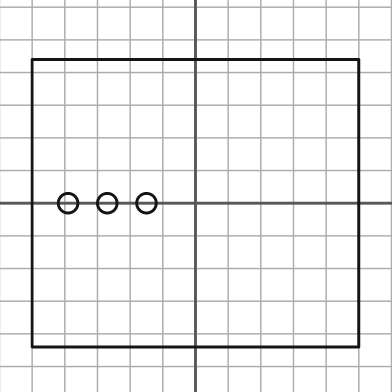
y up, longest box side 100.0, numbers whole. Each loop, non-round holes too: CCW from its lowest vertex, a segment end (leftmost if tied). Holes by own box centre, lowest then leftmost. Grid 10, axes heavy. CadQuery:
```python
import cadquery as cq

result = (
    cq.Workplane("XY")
    .moveTo(-50.0, -44.0)
    .lineTo(50.0, -44.0)
    .lineTo(50.0, 44.0)
    .lineTo(-50.0, 44.0)
    .close()
    .moveTo(-39.0, 0.0)
    .circle(3.0)
    .moveTo(-27.0, 0.0)
    .circle(3.0)
    .moveTo(-15.0, 0.0)
    .circle(3.0)
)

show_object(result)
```